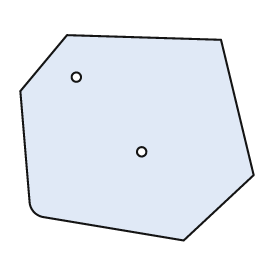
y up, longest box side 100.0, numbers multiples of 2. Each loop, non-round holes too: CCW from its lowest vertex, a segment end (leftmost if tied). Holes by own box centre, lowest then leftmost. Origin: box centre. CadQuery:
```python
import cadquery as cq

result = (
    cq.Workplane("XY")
    .moveTo(20.0, -44.0)
    .lineTo(50.0, -16.0)
    .lineTo(36.0, 42.0)
    .lineTo(-30.0, 44.0)
    .lineTo(-50.0, 20.0)
    .lineTo(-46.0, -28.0)
    .threePointArc((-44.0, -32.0), (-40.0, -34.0))
    .close()
    .moveTo(2.0, -6.0)
    .circle(2.0)
    .moveTo(-26.0, 26.0)
    .circle(2.0)
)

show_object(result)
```